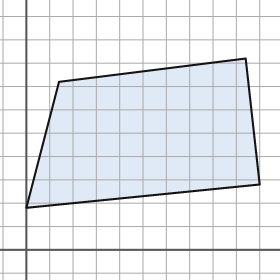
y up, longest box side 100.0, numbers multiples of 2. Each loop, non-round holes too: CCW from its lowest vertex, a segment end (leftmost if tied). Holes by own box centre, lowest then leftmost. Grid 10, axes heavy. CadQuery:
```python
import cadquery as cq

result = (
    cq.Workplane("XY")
    .moveTo(0.0, 18.0)
    .lineTo(100.0, 28.0)
    .lineTo(94.0, 82.0)
    .lineTo(14.0, 72.0)
    .close()
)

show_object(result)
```